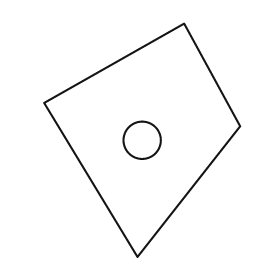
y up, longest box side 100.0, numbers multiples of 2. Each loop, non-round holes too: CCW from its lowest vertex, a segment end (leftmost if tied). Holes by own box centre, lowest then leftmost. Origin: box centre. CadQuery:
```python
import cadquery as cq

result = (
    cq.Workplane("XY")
    .moveTo(-2.0, -50.0)
    .lineTo(42.0, 6.0)
    .lineTo(18.0, 50.0)
    .lineTo(-42.0, 16.0)
    .close()
    .moveTo(0.0, 0.0)
    .circle(8.0)
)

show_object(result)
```